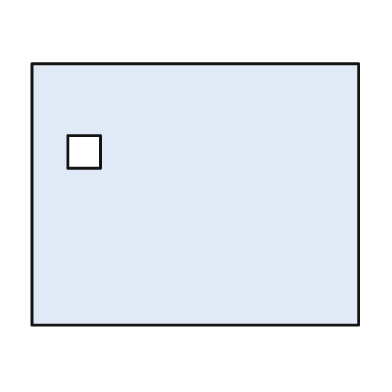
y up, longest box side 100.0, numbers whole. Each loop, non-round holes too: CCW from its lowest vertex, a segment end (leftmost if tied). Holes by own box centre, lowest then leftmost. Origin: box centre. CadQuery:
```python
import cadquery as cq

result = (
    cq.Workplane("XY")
    .moveTo(-50.0, -40.0)
    .lineTo(50.0, -40.0)
    .lineTo(50.0, 40.0)
    .lineTo(-50.0, 40.0)
    .close()
    .moveTo(-39.0, 8.0)
    .lineTo(-29.0, 8.0)
    .lineTo(-29.0, 18.0)
    .lineTo(-39.0, 18.0)
    .close()
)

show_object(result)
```